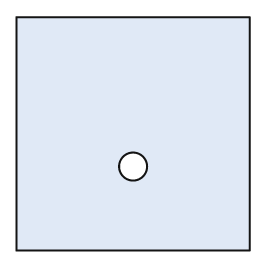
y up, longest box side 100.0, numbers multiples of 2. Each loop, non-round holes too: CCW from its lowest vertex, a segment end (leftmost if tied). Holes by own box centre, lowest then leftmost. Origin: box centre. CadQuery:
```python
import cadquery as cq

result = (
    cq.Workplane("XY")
    .moveTo(-50.0, -50.0)
    .lineTo(50.0, -50.0)
    .lineTo(50.0, 50.0)
    .lineTo(-50.0, 50.0)
    .close()
    .moveTo(0.0, -14.0)
    .circle(6.0)
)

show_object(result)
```